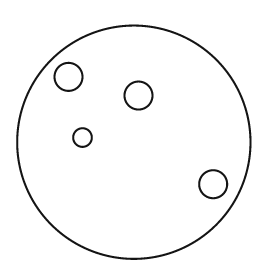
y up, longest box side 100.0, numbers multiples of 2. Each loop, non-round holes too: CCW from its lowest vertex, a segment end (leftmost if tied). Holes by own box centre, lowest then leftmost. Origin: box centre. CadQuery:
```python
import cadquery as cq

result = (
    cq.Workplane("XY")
    .moveTo(0.0, 0.0)
    .circle(50.0)
    .moveTo(34.0, -18.0)
    .circle(6.0)
    .moveTo(-22.0, 2.0)
    .circle(4.0)
    .moveTo(2.0, 20.0)
    .circle(6.0)
    .moveTo(-28.0, 28.0)
    .circle(6.0)
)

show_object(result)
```